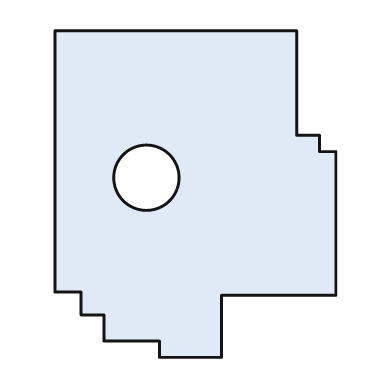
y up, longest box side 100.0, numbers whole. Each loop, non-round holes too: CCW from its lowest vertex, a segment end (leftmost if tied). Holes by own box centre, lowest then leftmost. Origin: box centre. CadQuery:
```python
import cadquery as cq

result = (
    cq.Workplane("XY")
    .moveTo(-11.0, -50.0)
    .lineTo(8.0, -50.0)
    .lineTo(8.0, -31.0)
    .lineTo(43.0, -31.0)
    .lineTo(43.0, 13.0)
    .lineTo(38.0, 13.0)
    .lineTo(38.0, 18.0)
    .lineTo(31.0, 18.0)
    .lineTo(31.0, 50.0)
    .lineTo(-43.0, 50.0)
    .lineTo(-43.0, -30.0)
    .lineTo(-35.0, -30.0)
    .lineTo(-35.0, -37.0)
    .lineTo(-28.0, -37.0)
    .lineTo(-28.0, -45.0)
    .lineTo(-11.0, -45.0)
    .close()
    .moveTo(-15.0, 5.0)
    .circle(10.0)
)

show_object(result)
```